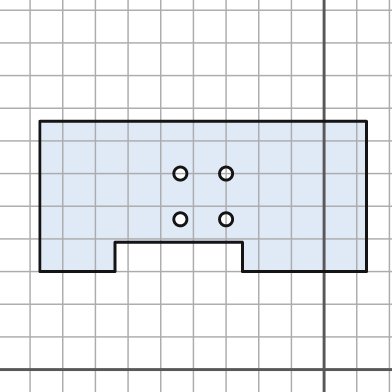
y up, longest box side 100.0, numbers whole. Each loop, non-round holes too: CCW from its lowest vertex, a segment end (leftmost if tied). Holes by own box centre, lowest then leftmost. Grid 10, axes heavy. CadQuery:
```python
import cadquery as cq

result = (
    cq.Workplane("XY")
    .moveTo(-87.0, 30.0)
    .lineTo(-64.0, 30.0)
    .lineTo(-64.0, 39.0)
    .lineTo(-25.0, 39.0)
    .lineTo(-25.0, 30.0)
    .lineTo(13.0, 30.0)
    .lineTo(13.0, 76.0)
    .lineTo(-87.0, 76.0)
    .close()
    .moveTo(-44.0, 46.0)
    .circle(2.0)
    .moveTo(-30.0, 46.0)
    .circle(2.0)
    .moveTo(-44.0, 60.0)
    .circle(2.0)
    .moveTo(-30.0, 60.0)
    .circle(2.0)
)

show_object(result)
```